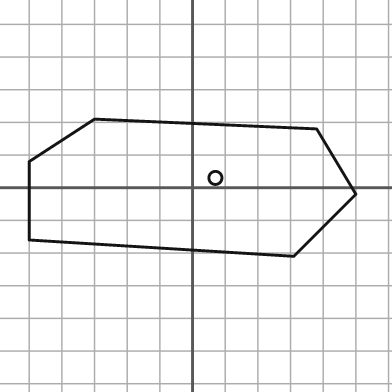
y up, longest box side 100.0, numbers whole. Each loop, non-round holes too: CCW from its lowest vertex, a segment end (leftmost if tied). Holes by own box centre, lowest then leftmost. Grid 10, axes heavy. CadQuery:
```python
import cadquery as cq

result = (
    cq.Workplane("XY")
    .moveTo(31.0, -21.0)
    .lineTo(50.0, -2.0)
    .lineTo(38.0, 18.0)
    .lineTo(-30.0, 21.0)
    .lineTo(-50.0, 8.0)
    .lineTo(-50.0, -16.0)
    .close()
    .moveTo(7.0, 3.0)
    .circle(2.0)
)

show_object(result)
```